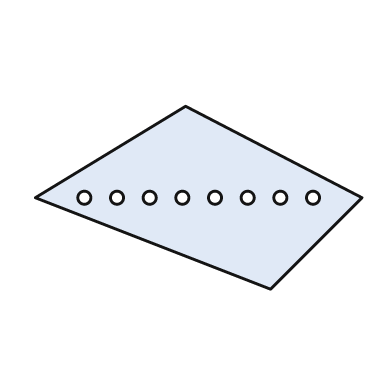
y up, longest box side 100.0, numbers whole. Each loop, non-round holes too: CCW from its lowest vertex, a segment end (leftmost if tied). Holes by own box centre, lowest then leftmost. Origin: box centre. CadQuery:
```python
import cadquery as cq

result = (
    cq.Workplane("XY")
    .moveTo(22.0, -28.0)
    .lineTo(50.0, 0.0)
    .lineTo(-4.0, 28.0)
    .lineTo(-50.0, 0.0)
    .close()
    .moveTo(-35.0, 0.0)
    .circle(2.0)
    .moveTo(-25.0, 0.0)
    .circle(2.0)
    .moveTo(-15.0, 0.0)
    .circle(2.0)
    .moveTo(-5.0, 0.0)
    .circle(2.0)
    .moveTo(5.0, 0.0)
    .circle(2.0)
    .moveTo(15.0, 0.0)
    .circle(2.0)
    .moveTo(25.0, 0.0)
    .circle(2.0)
    .moveTo(35.0, 0.0)
    .circle(2.0)
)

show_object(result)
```